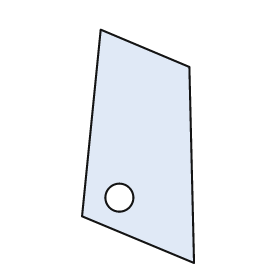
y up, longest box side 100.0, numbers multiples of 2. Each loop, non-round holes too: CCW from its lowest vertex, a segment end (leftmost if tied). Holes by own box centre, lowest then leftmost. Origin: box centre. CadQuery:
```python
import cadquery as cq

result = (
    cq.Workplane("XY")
    .moveTo(24.0, -50.0)
    .lineTo(22.0, 34.0)
    .lineTo(-16.0, 50.0)
    .lineTo(-24.0, -30.0)
    .close()
    .moveTo(-8.0, -22.0)
    .circle(6.0)
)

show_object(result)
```